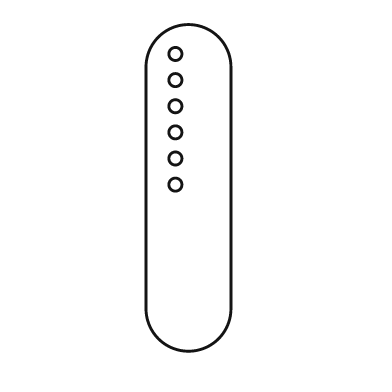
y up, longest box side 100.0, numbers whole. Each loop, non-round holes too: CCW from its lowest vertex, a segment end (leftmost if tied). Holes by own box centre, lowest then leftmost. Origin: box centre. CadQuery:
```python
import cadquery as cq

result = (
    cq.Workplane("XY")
    .moveTo(-13.0, -37.0)
    .threePointArc((0.0, -50.0), (13.0, -37.0))
    .lineTo(13.0, 37.0)
    .threePointArc((0.0, 50.0), (-13.0, 37.0))
    .close()
    .moveTo(-4.0, 1.0)
    .circle(2.0)
    .moveTo(-4.0, 9.0)
    .circle(2.0)
    .moveTo(-4.0, 17.0)
    .circle(2.0)
    .moveTo(-4.0, 25.0)
    .circle(2.0)
    .moveTo(-4.0, 33.0)
    .circle(2.0)
    .moveTo(-4.0, 41.0)
    .circle(2.0)
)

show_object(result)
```